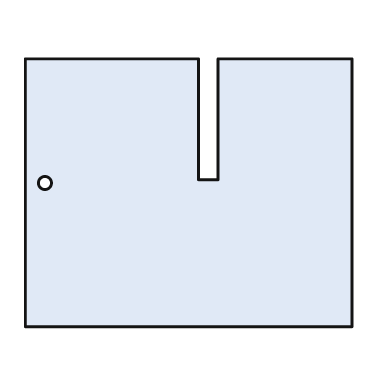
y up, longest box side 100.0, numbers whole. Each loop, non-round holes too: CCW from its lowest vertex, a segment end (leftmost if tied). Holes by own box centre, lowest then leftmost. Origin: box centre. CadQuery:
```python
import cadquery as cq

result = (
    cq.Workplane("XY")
    .moveTo(-50.0, -41.0)
    .lineTo(50.0, -41.0)
    .lineTo(50.0, 41.0)
    .lineTo(9.0, 41.0)
    .lineTo(9.0, 4.0)
    .lineTo(3.0, 4.0)
    .lineTo(3.0, 41.0)
    .lineTo(-50.0, 41.0)
    .close()
    .moveTo(-44.0, 3.0)
    .circle(2.0)
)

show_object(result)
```